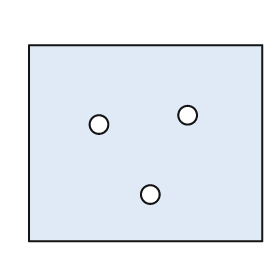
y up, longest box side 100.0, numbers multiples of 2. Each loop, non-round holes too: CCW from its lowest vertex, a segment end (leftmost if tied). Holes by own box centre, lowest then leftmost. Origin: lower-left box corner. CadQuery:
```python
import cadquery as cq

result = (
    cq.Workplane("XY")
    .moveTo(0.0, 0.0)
    .lineTo(100.0, 0.0)
    .lineTo(100.0, 84.0)
    .lineTo(0.0, 84.0)
    .close()
    .moveTo(52.0, 20.0)
    .circle(4.0)
    .moveTo(30.0, 50.0)
    .circle(4.0)
    .moveTo(68.0, 54.0)
    .circle(4.0)
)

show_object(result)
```